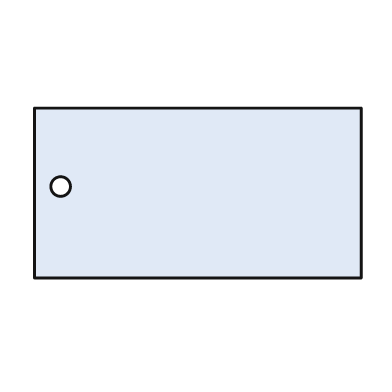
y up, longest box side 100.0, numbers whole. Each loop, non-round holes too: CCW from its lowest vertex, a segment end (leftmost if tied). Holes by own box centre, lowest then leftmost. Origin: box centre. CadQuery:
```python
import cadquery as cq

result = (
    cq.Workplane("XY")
    .moveTo(-50.0, -26.0)
    .lineTo(50.0, -26.0)
    .lineTo(50.0, 26.0)
    .lineTo(-50.0, 26.0)
    .close()
    .moveTo(-42.0, 2.0)
    .circle(3.0)
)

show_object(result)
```